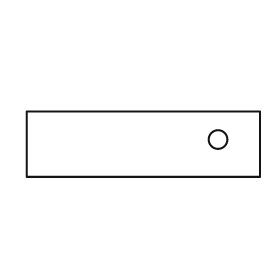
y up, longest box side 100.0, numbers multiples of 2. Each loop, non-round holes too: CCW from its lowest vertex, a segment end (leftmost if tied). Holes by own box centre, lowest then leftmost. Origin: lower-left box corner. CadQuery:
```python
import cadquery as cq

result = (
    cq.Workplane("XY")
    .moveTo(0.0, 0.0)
    .lineTo(100.0, 0.0)
    .lineTo(100.0, 28.0)
    .lineTo(0.0, 28.0)
    .close()
    .moveTo(82.0, 16.0)
    .circle(4.0)
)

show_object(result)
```